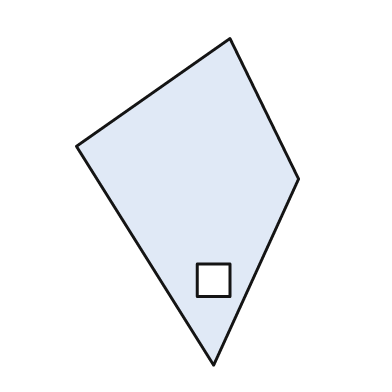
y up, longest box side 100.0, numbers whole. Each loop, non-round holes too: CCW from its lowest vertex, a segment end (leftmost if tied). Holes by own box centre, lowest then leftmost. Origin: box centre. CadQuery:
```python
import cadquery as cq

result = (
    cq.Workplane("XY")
    .moveTo(8.0, -50.0)
    .lineTo(34.0, 7.0)
    .lineTo(13.0, 50.0)
    .lineTo(-34.0, 17.0)
    .close()
    .moveTo(3.0, -29.0)
    .lineTo(13.0, -29.0)
    .lineTo(13.0, -19.0)
    .lineTo(3.0, -19.0)
    .close()
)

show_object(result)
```